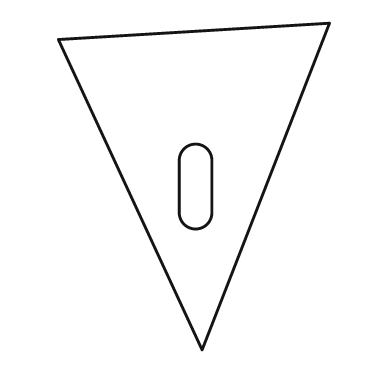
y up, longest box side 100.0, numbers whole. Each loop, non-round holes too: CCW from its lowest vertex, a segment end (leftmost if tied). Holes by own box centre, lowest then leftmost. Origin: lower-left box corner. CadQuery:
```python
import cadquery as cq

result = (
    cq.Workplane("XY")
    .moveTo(44.0, 0.0)
    .lineTo(83.0, 100.0)
    .lineTo(0.0, 95.0)
    .close()
    .moveTo(37.0, 42.0)
    .threePointArc((42.0, 37.0), (47.0, 42.0))
    .lineTo(47.0, 58.0)
    .threePointArc((42.0, 63.0), (37.0, 58.0))
    .close()
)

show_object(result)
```